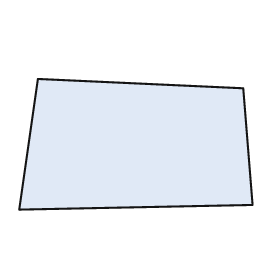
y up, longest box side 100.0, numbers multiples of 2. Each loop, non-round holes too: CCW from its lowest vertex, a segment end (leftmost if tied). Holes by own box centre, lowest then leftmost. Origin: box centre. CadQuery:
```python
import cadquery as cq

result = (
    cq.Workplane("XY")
    .moveTo(-50.0, -28.0)
    .lineTo(50.0, -26.0)
    .lineTo(46.0, 24.0)
    .lineTo(-42.0, 28.0)
    .close()
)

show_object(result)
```